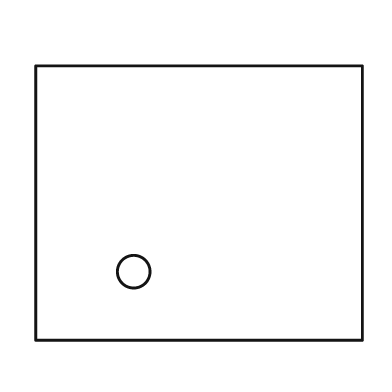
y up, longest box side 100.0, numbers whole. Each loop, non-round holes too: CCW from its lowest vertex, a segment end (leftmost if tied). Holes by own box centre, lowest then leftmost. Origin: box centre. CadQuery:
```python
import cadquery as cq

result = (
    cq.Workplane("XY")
    .moveTo(-50.0, -42.0)
    .lineTo(50.0, -42.0)
    .lineTo(50.0, 42.0)
    .lineTo(-50.0, 42.0)
    .close()
    .moveTo(-20.0, -21.0)
    .circle(5.0)
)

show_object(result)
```